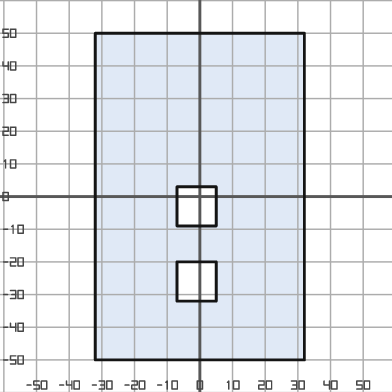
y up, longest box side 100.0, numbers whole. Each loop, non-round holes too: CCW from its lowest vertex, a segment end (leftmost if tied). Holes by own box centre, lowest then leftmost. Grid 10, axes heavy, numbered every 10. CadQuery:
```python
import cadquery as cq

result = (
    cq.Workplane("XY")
    .moveTo(-32.0, -50.0)
    .lineTo(32.0, -50.0)
    .lineTo(32.0, 50.0)
    .lineTo(-32.0, 50.0)
    .close()
    .moveTo(-7.0, -32.0)
    .lineTo(5.0, -32.0)
    .lineTo(5.0, -20.0)
    .lineTo(-7.0, -20.0)
    .close()
    .moveTo(-7.0, -9.0)
    .lineTo(5.0, -9.0)
    .lineTo(5.0, 3.0)
    .lineTo(-7.0, 3.0)
    .close()
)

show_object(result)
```